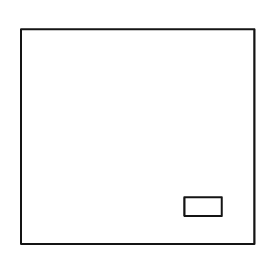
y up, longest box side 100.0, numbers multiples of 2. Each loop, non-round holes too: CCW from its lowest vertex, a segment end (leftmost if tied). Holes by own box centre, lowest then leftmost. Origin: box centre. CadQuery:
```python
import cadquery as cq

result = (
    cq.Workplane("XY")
    .moveTo(-50.0, -46.0)
    .lineTo(50.0, -46.0)
    .lineTo(50.0, 46.0)
    .lineTo(-50.0, 46.0)
    .close()
    .moveTo(20.0, -34.0)
    .lineTo(36.0, -34.0)
    .lineTo(36.0, -26.0)
    .lineTo(20.0, -26.0)
    .close()
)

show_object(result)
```